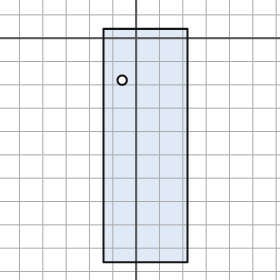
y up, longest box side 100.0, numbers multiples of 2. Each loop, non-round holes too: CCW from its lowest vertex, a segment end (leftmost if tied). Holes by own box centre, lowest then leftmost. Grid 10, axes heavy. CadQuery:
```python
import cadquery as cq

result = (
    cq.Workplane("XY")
    .moveTo(-14.0, -96.0)
    .lineTo(22.0, -96.0)
    .lineTo(22.0, 4.0)
    .lineTo(-14.0, 4.0)
    .close()
    .moveTo(-6.0, -18.0)
    .circle(2.0)
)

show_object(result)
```